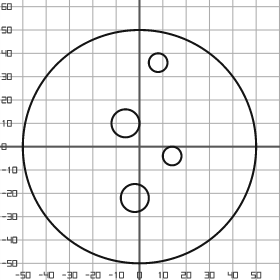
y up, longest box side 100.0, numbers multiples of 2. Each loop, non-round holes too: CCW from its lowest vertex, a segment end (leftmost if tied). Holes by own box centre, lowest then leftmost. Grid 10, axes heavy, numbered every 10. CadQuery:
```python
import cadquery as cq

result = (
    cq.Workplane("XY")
    .moveTo(0.0, 0.0)
    .circle(50.0)
    .moveTo(-2.0, -22.0)
    .circle(6.0)
    .moveTo(14.0, -4.0)
    .circle(4.0)
    .moveTo(-6.0, 10.0)
    .circle(6.0)
    .moveTo(8.0, 36.0)
    .circle(4.0)
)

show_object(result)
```